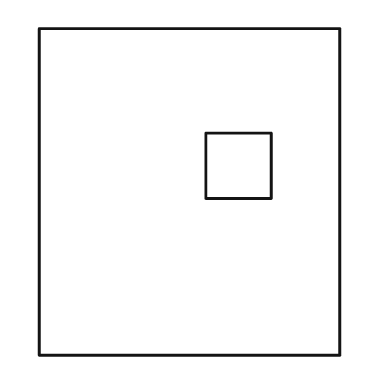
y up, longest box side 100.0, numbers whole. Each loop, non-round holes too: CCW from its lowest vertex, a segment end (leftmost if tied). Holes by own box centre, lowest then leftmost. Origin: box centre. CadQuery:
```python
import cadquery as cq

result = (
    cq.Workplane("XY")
    .moveTo(-46.0, -50.0)
    .lineTo(46.0, -50.0)
    .lineTo(46.0, 50.0)
    .lineTo(-46.0, 50.0)
    .close()
    .moveTo(5.0, -2.0)
    .lineTo(25.0, -2.0)
    .lineTo(25.0, 18.0)
    .lineTo(5.0, 18.0)
    .close()
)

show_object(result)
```